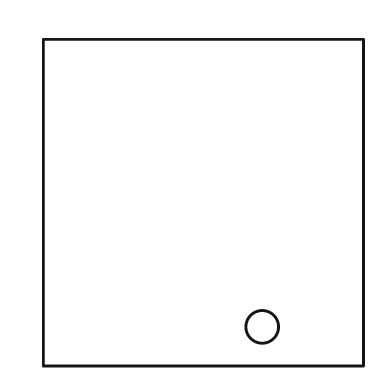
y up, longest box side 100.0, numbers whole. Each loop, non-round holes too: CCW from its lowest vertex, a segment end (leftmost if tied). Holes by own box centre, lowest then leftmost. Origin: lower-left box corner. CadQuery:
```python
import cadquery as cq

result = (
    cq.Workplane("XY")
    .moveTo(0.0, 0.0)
    .lineTo(98.0, 0.0)
    .lineTo(98.0, 100.0)
    .lineTo(0.0, 100.0)
    .close()
    .moveTo(67.0, 12.0)
    .circle(5.0)
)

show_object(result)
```